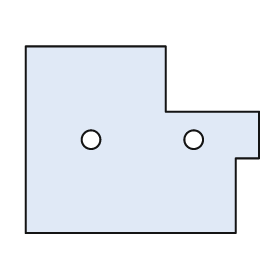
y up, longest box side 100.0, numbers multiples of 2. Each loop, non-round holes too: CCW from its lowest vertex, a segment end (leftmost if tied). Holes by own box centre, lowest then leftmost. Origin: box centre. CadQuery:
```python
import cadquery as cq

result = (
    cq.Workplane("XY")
    .moveTo(-50.0, -40.0)
    .lineTo(40.0, -40.0)
    .lineTo(40.0, -8.0)
    .lineTo(50.0, -8.0)
    .lineTo(50.0, 12.0)
    .lineTo(10.0, 12.0)
    .lineTo(10.0, 40.0)
    .lineTo(-50.0, 40.0)
    .close()
    .moveTo(-22.0, 0.0)
    .circle(4.0)
    .moveTo(22.0, 0.0)
    .circle(4.0)
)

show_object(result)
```